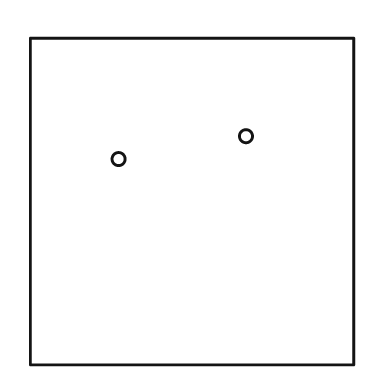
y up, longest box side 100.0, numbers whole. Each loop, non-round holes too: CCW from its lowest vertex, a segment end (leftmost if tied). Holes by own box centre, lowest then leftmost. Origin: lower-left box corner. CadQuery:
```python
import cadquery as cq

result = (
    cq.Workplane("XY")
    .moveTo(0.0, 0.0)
    .lineTo(99.0, 0.0)
    .lineTo(99.0, 100.0)
    .lineTo(0.0, 100.0)
    .close()
    .moveTo(27.0, 63.0)
    .circle(2.0)
    .moveTo(66.0, 70.0)
    .circle(2.0)
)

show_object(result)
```